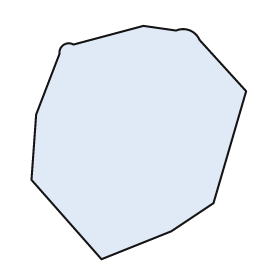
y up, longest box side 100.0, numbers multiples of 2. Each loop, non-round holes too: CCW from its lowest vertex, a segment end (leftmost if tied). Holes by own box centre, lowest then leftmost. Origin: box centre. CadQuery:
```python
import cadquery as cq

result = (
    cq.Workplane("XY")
    .moveTo(-16.0, -50.0)
    .lineTo(14.0, -38.0)
    .lineTo(32.0, -26.0)
    .lineTo(46.0, 22.0)
    .lineTo(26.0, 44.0)
    .threePointArc((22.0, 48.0), (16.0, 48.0))
    .lineTo(2.0, 50.0)
    .lineTo(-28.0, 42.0)
    .threePointArc((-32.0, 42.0), (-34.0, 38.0))
    .lineTo(-44.0, 12.0)
    .lineTo(-46.0, -16.0)
    .close()
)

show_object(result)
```